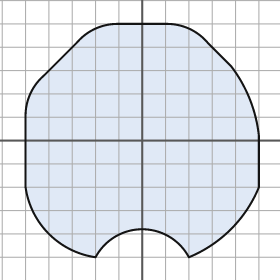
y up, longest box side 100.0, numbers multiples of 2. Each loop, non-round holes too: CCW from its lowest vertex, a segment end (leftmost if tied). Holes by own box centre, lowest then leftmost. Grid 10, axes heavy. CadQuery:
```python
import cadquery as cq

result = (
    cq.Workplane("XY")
    .moveTo(-20.0, -50.0)
    .threePointArc((0.0, -38.0), (20.0, -50.0))
    .threePointArc((38.0, -38.0), (50.0, -20.0))
    .lineTo(50.0, 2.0)
    .threePointArc((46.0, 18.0), (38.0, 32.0))
    .lineTo(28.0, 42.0)
    .threePointArc((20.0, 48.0), (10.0, 50.0))
    .lineTo(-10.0, 50.0)
    .threePointArc((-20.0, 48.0), (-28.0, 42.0))
    .lineTo(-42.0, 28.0)
    .threePointArc((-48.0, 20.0), (-50.0, 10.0))
    .lineTo(-50.0, -20.0)
    .threePointArc((-40.0, -40.0), (-20.0, -50.0))
    .close()
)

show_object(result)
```